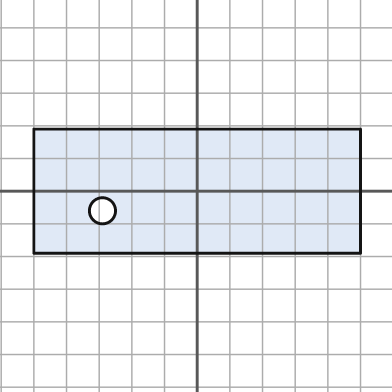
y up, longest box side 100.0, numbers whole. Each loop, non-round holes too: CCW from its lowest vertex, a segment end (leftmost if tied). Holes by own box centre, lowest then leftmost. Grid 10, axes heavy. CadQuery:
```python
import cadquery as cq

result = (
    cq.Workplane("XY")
    .moveTo(-50.0, -19.0)
    .lineTo(50.0, -19.0)
    .lineTo(50.0, 19.0)
    .lineTo(-50.0, 19.0)
    .close()
    .moveTo(-29.0, -6.0)
    .circle(4.0)
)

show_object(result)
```